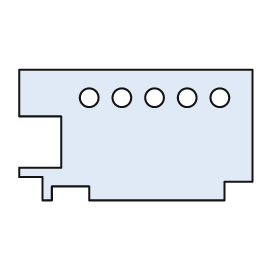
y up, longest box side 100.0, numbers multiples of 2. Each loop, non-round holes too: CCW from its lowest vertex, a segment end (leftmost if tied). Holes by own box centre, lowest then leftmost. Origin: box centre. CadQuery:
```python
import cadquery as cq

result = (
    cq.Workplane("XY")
    .moveTo(-40.0, -28.0)
    .lineTo(-36.0, -28.0)
    .lineTo(-36.0, -22.0)
    .lineTo(-20.0, -22.0)
    .lineTo(-20.0, -28.0)
    .lineTo(38.0, -28.0)
    .lineTo(38.0, -20.0)
    .lineTo(50.0, -20.0)
    .lineTo(50.0, 28.0)
    .lineTo(-50.0, 28.0)
    .lineTo(-50.0, 8.0)
    .lineTo(-32.0, 8.0)
    .lineTo(-32.0, -14.0)
    .lineTo(-50.0, -14.0)
    .lineTo(-50.0, -18.0)
    .lineTo(-40.0, -18.0)
    .close()
    .moveTo(-20.0, 16.0)
    .circle(4.0)
    .moveTo(-6.0, 16.0)
    .circle(4.0)
    .moveTo(8.0, 16.0)
    .circle(4.0)
    .moveTo(22.0, 16.0)
    .circle(4.0)
    .moveTo(36.0, 16.0)
    .circle(4.0)
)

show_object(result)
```